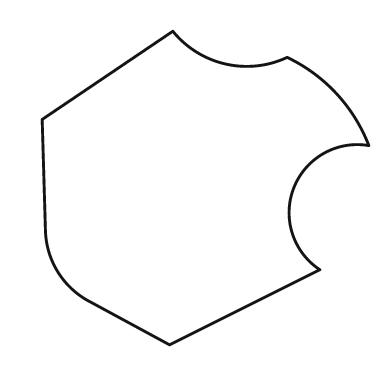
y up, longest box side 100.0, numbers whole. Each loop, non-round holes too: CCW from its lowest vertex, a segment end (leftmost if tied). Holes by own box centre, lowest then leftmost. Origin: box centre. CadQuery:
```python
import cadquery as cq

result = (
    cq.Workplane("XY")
    .moveTo(-11.0, -48.0)
    .lineTo(35.0, -25.0)
    .threePointArc((27.0, 0.0), (50.0, 13.0))
    .threePointArc((40.0, 29.0), (25.0, 40.0))
    .threePointArc((6.0, 38.0), (-10.0, 48.0))
    .lineTo(-50.0, 21.0)
    .lineTo(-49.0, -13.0)
    .threePointArc((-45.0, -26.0), (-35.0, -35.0))
    .close()
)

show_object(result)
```